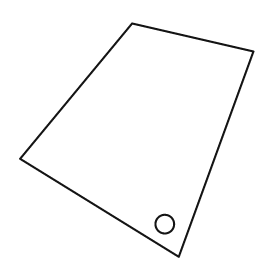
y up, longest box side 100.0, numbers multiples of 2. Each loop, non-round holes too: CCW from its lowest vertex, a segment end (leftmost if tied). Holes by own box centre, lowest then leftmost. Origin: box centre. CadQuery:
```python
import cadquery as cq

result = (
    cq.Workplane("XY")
    .moveTo(18.0, -50.0)
    .lineTo(50.0, 38.0)
    .lineTo(-2.0, 50.0)
    .lineTo(-50.0, -8.0)
    .close()
    .moveTo(12.0, -36.0)
    .circle(4.0)
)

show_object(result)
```